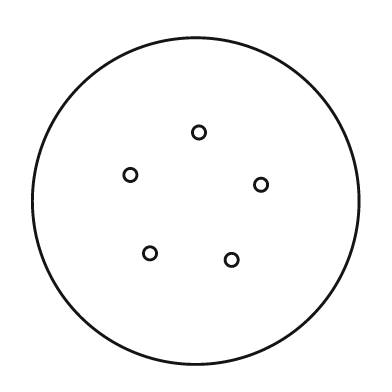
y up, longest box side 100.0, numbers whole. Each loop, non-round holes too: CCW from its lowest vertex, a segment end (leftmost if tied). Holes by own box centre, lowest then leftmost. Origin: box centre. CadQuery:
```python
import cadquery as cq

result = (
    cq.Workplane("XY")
    .moveTo(0.0, 0.0)
    .circle(50.0)
    .moveTo(11.0, -18.0)
    .circle(2.0)
    .moveTo(-14.0, -16.0)
    .circle(2.0)
    .moveTo(20.0, 5.0)
    .circle(2.0)
    .moveTo(-20.0, 8.0)
    .circle(2.0)
    .moveTo(1.0, 21.0)
    .circle(2.0)
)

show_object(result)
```